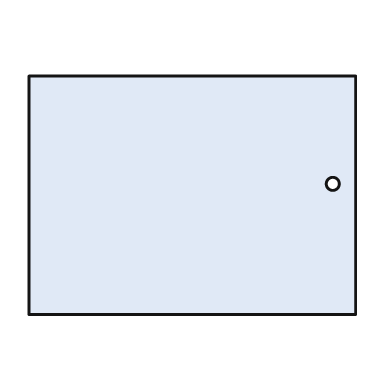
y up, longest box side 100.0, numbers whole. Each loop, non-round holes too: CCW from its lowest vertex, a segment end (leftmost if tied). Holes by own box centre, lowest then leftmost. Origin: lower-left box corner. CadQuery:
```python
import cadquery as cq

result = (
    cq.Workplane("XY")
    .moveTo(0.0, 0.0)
    .lineTo(100.0, 0.0)
    .lineTo(100.0, 73.0)
    .lineTo(0.0, 73.0)
    .close()
    .moveTo(93.0, 40.0)
    .circle(2.0)
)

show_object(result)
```